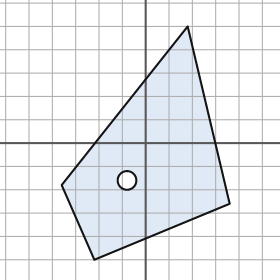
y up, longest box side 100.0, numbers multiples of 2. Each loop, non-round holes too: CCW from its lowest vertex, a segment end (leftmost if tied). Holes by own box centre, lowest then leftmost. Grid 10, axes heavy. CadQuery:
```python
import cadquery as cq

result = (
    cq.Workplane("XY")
    .moveTo(-22.0, -50.0)
    .lineTo(36.0, -26.0)
    .lineTo(18.0, 50.0)
    .lineTo(-36.0, -18.0)
    .close()
    .moveTo(-8.0, -16.0)
    .circle(4.0)
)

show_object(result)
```